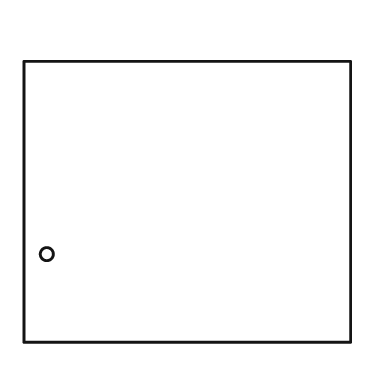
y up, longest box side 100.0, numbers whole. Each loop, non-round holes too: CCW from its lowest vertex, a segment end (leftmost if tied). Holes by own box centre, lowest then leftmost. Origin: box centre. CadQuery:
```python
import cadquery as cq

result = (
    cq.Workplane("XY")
    .moveTo(-50.0, -43.0)
    .lineTo(50.0, -43.0)
    .lineTo(50.0, 43.0)
    .lineTo(-50.0, 43.0)
    .close()
    .moveTo(-43.0, -16.0)
    .circle(2.0)
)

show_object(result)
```